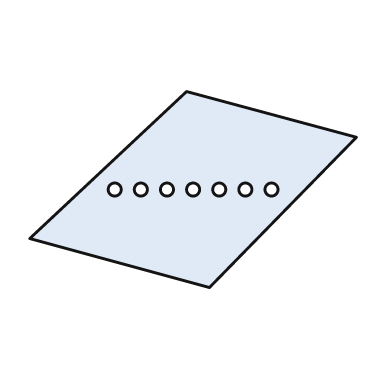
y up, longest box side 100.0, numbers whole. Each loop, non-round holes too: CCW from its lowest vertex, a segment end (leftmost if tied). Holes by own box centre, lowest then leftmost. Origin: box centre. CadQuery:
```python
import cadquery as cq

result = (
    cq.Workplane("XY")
    .moveTo(5.0, -30.0)
    .lineTo(50.0, 16.0)
    .lineTo(-2.0, 30.0)
    .lineTo(-50.0, -15.0)
    .close()
    .moveTo(-24.0, 0.0)
    .circle(2.0)
    .moveTo(-16.0, 0.0)
    .circle(2.0)
    .moveTo(-8.0, 0.0)
    .circle(2.0)
    .moveTo(0.0, 0.0)
    .circle(2.0)
    .moveTo(8.0, 0.0)
    .circle(2.0)
    .moveTo(16.0, 0.0)
    .circle(2.0)
    .moveTo(24.0, 0.0)
    .circle(2.0)
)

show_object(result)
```